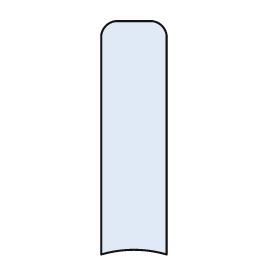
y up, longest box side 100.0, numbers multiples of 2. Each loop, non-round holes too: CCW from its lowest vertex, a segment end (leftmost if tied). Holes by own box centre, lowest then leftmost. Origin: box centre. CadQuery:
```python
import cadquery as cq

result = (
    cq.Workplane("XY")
    .moveTo(-14.0, -50.0)
    .threePointArc((0.0, -48.0), (14.0, -50.0))
    .lineTo(14.0, 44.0)
    .threePointArc((12.0, 48.0), (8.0, 50.0))
    .lineTo(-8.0, 50.0)
    .threePointArc((-12.0, 48.0), (-14.0, 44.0))
    .close()
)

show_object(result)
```